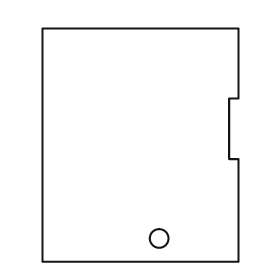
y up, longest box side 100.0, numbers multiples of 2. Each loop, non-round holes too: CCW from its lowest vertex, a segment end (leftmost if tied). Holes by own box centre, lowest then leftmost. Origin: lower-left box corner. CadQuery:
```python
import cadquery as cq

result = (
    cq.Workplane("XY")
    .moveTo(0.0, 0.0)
    .lineTo(84.0, 0.0)
    .lineTo(84.0, 44.0)
    .lineTo(80.0, 44.0)
    .lineTo(80.0, 70.0)
    .lineTo(84.0, 70.0)
    .lineTo(84.0, 100.0)
    .lineTo(0.0, 100.0)
    .close()
    .moveTo(50.0, 10.0)
    .circle(4.0)
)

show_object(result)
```